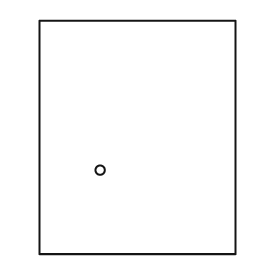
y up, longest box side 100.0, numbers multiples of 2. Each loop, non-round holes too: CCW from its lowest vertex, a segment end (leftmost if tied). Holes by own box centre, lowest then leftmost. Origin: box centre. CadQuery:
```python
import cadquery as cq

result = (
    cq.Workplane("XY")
    .moveTo(-42.0, -50.0)
    .lineTo(42.0, -50.0)
    .lineTo(42.0, 50.0)
    .lineTo(-42.0, 50.0)
    .close()
    .moveTo(-16.0, -14.0)
    .circle(2.0)
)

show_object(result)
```